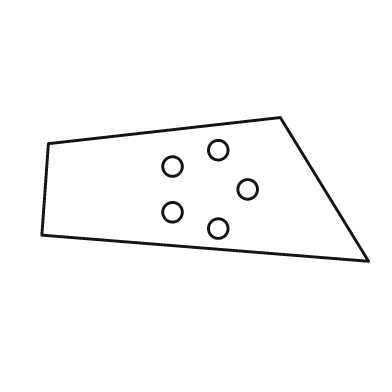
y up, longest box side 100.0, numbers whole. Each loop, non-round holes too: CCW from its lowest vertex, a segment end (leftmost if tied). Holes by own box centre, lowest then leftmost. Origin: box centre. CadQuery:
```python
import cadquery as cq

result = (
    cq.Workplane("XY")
    .moveTo(50.0, -22.0)
    .lineTo(23.0, 22.0)
    .lineTo(-48.0, 14.0)
    .lineTo(-50.0, -14.0)
    .close()
    .moveTo(4.0, -12.0)
    .circle(3.0)
    .moveTo(-10.0, -7.0)
    .circle(3.0)
    .moveTo(13.0, 0.0)
    .circle(3.0)
    .moveTo(-10.0, 7.0)
    .circle(3.0)
    .moveTo(4.0, 12.0)
    .circle(3.0)
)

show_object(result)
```